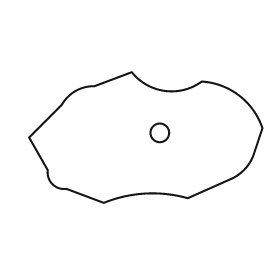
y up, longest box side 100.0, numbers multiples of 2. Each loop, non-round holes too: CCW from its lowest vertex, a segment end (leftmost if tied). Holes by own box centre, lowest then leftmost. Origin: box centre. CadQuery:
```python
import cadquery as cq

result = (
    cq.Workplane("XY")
    .moveTo(-18.0, -28.0)
    .threePointArc((0.0, -24.0), (18.0, -26.0))
    .lineTo(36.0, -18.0)
    .threePointArc((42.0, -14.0), (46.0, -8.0))
    .lineTo(50.0, 4.0)
    .threePointArc((40.0, 18.0), (24.0, 24.0))
    .threePointArc((8.0, 20.0), (-6.0, 28.0))
    .lineTo(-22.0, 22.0)
    .threePointArc((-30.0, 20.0), (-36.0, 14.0))
    .lineTo(-50.0, 0.0)
    .lineTo(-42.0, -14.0)
    .threePointArc((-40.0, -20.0), (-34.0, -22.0))
    .close()
    .moveTo(6.0, 2.0)
    .circle(4.0)
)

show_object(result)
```